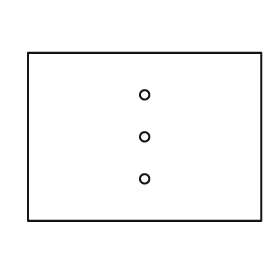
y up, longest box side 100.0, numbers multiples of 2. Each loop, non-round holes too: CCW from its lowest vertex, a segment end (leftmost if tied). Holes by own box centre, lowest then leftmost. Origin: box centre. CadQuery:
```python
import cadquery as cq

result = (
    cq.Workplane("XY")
    .moveTo(-50.0, -36.0)
    .lineTo(50.0, -36.0)
    .lineTo(50.0, 36.0)
    .lineTo(-50.0, 36.0)
    .close()
    .moveTo(0.0, -18.0)
    .circle(2.0)
    .moveTo(0.0, 0.0)
    .circle(2.0)
    .moveTo(0.0, 18.0)
    .circle(2.0)
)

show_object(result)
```